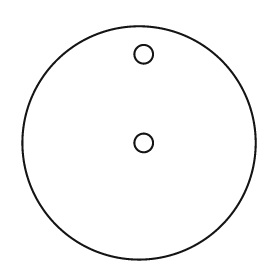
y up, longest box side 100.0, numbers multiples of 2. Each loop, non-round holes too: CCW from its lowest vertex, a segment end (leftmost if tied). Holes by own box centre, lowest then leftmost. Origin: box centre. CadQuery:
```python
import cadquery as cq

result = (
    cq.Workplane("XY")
    .moveTo(0.0, 0.0)
    .circle(50.0)
    .moveTo(2.0, 0.0)
    .circle(4.0)
    .moveTo(2.0, 38.0)
    .circle(4.0)
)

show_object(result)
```